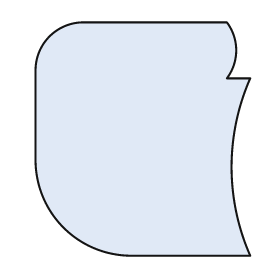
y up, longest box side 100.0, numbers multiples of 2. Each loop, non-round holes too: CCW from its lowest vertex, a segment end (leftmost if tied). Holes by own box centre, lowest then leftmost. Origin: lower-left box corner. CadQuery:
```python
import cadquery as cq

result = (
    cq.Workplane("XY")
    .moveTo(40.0, 0.0)
    .lineTo(92.0, 0.0)
    .threePointArc((84.0, 38.0), (92.0, 76.0))
    .lineTo(82.0, 76.0)
    .threePointArc((86.0, 88.0), (82.0, 100.0))
    .lineTo(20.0, 100.0)
    .threePointArc((6.0, 94.0), (0.0, 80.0))
    .lineTo(0.0, 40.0)
    .threePointArc((12.0, 12.0), (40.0, 0.0))
    .close()
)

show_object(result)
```